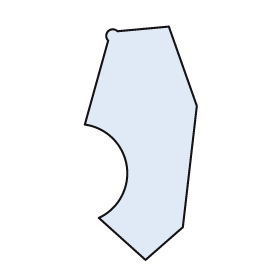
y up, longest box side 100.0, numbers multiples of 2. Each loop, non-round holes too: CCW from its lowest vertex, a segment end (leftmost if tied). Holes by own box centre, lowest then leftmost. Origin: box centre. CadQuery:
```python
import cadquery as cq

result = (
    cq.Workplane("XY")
    .moveTo(2.0, -50.0)
    .lineTo(18.0, -36.0)
    .lineTo(24.0, 16.0)
    .lineTo(12.0, 50.0)
    .lineTo(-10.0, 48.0)
    .threePointArc((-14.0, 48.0), (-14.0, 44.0))
    .lineTo(-24.0, 8.0)
    .threePointArc((-6.0, -10.0), (-18.0, -32.0))
    .close()
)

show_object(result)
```